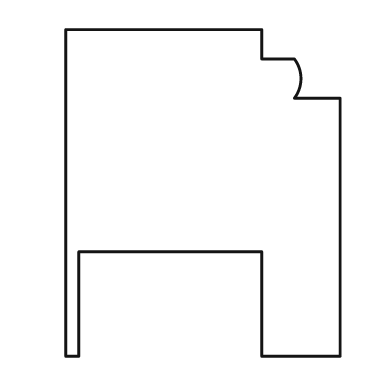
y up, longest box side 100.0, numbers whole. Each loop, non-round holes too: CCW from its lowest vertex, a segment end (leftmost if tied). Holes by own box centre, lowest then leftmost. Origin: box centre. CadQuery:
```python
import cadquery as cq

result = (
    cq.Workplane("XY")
    .moveTo(-42.0, -50.0)
    .lineTo(-38.0, -50.0)
    .lineTo(-38.0, -18.0)
    .lineTo(18.0, -18.0)
    .lineTo(18.0, -50.0)
    .lineTo(42.0, -50.0)
    .lineTo(42.0, 29.0)
    .lineTo(28.0, 29.0)
    .threePointArc((30.0, 35.0), (28.0, 41.0))
    .lineTo(18.0, 41.0)
    .lineTo(18.0, 50.0)
    .lineTo(-42.0, 50.0)
    .close()
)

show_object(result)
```